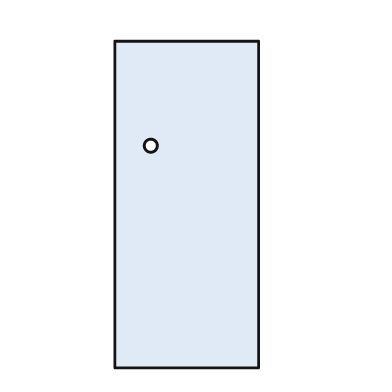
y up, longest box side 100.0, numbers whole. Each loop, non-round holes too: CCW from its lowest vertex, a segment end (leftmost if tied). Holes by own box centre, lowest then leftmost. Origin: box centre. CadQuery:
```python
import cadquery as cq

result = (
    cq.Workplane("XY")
    .moveTo(-22.0, -50.0)
    .lineTo(22.0, -50.0)
    .lineTo(22.0, 50.0)
    .lineTo(-22.0, 50.0)
    .close()
    .moveTo(-11.0, 18.0)
    .circle(2.0)
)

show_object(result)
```